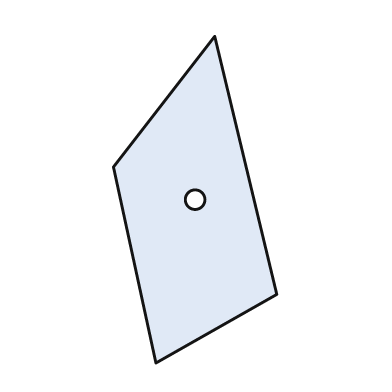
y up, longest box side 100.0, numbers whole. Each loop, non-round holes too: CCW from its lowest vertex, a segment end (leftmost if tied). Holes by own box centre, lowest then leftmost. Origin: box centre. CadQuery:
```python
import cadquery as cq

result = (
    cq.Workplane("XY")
    .moveTo(-12.0, -50.0)
    .lineTo(25.0, -29.0)
    .lineTo(6.0, 50.0)
    .lineTo(-25.0, 10.0)
    .close()
    .moveTo(0.0, 0.0)
    .circle(3.0)
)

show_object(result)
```